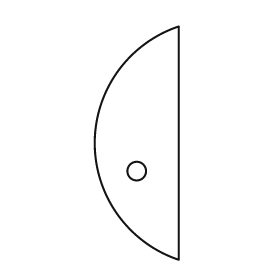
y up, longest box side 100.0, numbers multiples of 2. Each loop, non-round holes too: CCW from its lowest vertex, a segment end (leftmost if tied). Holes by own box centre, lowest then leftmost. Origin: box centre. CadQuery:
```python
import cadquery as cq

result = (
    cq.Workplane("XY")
    .moveTo(18.0, -50.0)
    .lineTo(18.0, 50.0)
    .threePointArc((-18.0, 0.0), (18.0, -50.0))
    .close()
    .moveTo(0.0, -12.0)
    .circle(4.0)
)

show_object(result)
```